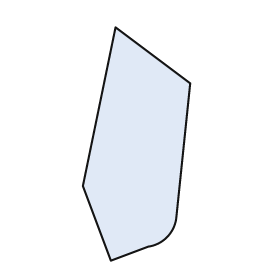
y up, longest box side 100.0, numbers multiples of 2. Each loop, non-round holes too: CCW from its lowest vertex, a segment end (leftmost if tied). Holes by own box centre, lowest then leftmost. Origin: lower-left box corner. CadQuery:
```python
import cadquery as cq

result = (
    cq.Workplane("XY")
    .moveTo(12.0, 0.0)
    .lineTo(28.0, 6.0)
    .threePointArc((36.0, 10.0), (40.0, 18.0))
    .lineTo(46.0, 76.0)
    .lineTo(14.0, 100.0)
    .lineTo(0.0, 32.0)
    .close()
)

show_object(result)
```